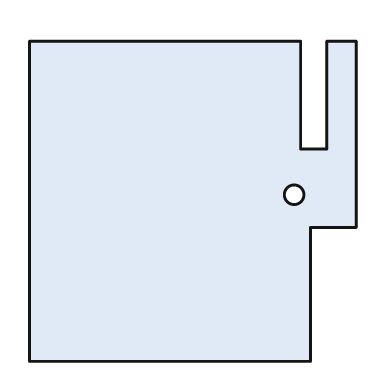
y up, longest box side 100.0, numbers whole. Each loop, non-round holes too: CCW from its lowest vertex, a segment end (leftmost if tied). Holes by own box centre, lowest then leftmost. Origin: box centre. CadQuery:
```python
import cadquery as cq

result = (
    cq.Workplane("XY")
    .moveTo(-50.0, -49.0)
    .lineTo(36.0, -49.0)
    .lineTo(36.0, -8.0)
    .lineTo(50.0, -8.0)
    .lineTo(50.0, 49.0)
    .lineTo(41.0, 49.0)
    .lineTo(41.0, 16.0)
    .lineTo(33.0, 16.0)
    .lineTo(33.0, 49.0)
    .lineTo(-50.0, 49.0)
    .close()
    .moveTo(31.0, 2.0)
    .circle(3.0)
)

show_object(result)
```